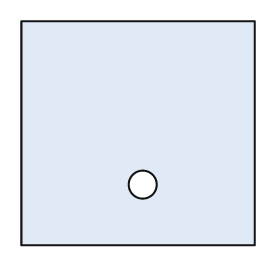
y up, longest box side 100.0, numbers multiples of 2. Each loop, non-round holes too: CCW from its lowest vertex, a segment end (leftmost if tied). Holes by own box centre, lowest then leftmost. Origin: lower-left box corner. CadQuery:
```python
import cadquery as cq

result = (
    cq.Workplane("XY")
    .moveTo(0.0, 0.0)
    .lineTo(100.0, 0.0)
    .lineTo(100.0, 96.0)
    .lineTo(0.0, 96.0)
    .close()
    .moveTo(52.0, 26.0)
    .circle(6.0)
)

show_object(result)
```